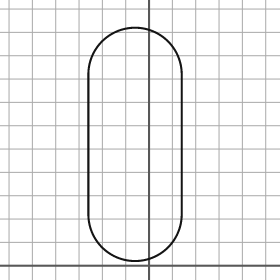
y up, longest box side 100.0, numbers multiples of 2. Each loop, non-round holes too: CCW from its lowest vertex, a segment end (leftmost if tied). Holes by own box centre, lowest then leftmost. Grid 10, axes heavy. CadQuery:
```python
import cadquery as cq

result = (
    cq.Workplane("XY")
    .moveTo(-26.0, 22.0)
    .threePointArc((-6.0, 2.0), (14.0, 22.0))
    .lineTo(14.0, 82.0)
    .threePointArc((-6.0, 102.0), (-26.0, 82.0))
    .close()
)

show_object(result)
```